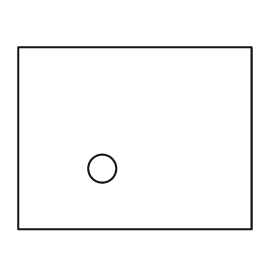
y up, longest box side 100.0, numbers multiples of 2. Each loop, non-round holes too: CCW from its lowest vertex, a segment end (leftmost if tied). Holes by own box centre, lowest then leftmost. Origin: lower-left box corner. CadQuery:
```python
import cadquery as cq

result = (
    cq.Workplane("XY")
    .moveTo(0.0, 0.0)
    .lineTo(100.0, 0.0)
    .lineTo(100.0, 78.0)
    .lineTo(0.0, 78.0)
    .close()
    .moveTo(36.0, 26.0)
    .circle(6.0)
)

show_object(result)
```